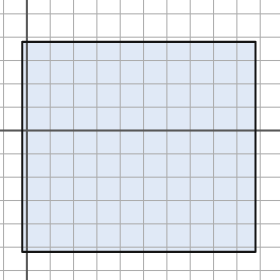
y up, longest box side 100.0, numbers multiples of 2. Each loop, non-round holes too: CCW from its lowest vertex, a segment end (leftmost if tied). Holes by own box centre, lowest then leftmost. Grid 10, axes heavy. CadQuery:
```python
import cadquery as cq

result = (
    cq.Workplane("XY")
    .moveTo(-2.0, -52.0)
    .lineTo(98.0, -52.0)
    .lineTo(98.0, 38.0)
    .lineTo(-2.0, 38.0)
    .close()
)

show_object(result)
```